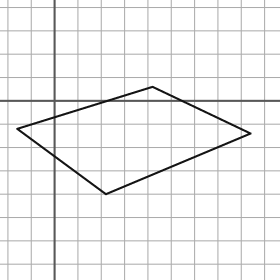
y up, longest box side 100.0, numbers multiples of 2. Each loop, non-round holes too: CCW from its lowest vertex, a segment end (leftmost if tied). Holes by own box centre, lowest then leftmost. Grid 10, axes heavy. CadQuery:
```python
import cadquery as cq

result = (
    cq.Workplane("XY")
    .moveTo(22.0, -40.0)
    .lineTo(84.0, -14.0)
    .lineTo(42.0, 6.0)
    .lineTo(-16.0, -12.0)
    .close()
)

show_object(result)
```